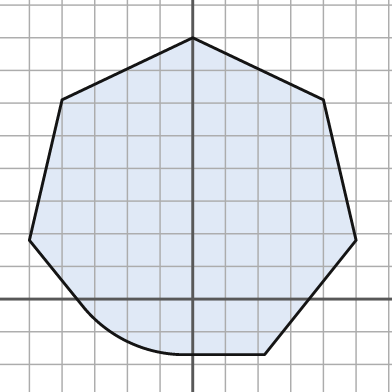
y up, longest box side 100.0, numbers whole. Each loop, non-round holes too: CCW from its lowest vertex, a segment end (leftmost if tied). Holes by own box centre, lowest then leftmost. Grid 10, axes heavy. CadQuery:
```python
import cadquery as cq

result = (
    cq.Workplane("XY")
    .moveTo(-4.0, -17.0)
    .lineTo(22.0, -17.0)
    .lineTo(50.0, 18.0)
    .lineTo(40.0, 61.0)
    .lineTo(0.0, 80.0)
    .lineTo(-40.0, 61.0)
    .lineTo(-50.0, 18.0)
    .lineTo(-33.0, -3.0)
    .threePointArc((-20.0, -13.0), (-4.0, -17.0))
    .close()
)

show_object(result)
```